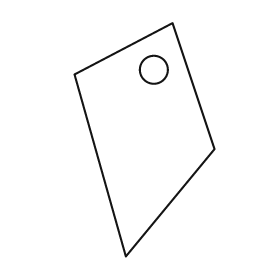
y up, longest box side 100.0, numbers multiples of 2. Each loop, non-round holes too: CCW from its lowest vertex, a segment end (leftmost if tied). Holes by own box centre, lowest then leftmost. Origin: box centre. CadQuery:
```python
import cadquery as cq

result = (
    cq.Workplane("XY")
    .moveTo(-8.0, -50.0)
    .lineTo(30.0, -4.0)
    .lineTo(12.0, 50.0)
    .lineTo(-30.0, 28.0)
    .close()
    .moveTo(4.0, 30.0)
    .circle(6.0)
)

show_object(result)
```